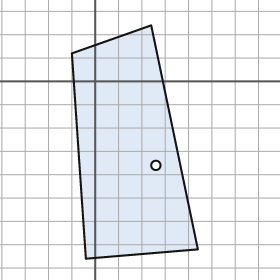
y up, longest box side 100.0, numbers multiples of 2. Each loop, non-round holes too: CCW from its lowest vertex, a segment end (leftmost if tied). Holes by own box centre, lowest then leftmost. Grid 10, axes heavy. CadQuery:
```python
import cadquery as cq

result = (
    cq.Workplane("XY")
    .moveTo(-4.0, -76.0)
    .lineTo(44.0, -72.0)
    .lineTo(24.0, 24.0)
    .lineTo(-10.0, 12.0)
    .close()
    .moveTo(26.0, -36.0)
    .circle(2.0)
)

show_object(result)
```